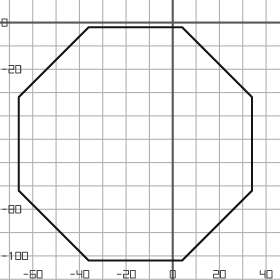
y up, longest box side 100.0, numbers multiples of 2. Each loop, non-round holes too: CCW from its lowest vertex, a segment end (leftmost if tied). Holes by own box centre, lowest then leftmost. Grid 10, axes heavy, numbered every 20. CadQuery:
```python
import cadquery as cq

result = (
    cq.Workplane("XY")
    .moveTo(-36.0, -102.0)
    .lineTo(4.0, -102.0)
    .lineTo(34.0, -72.0)
    .lineTo(34.0, -32.0)
    .lineTo(4.0, -2.0)
    .lineTo(-36.0, -2.0)
    .lineTo(-66.0, -32.0)
    .lineTo(-66.0, -72.0)
    .close()
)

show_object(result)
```